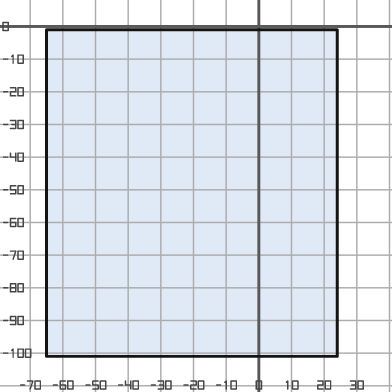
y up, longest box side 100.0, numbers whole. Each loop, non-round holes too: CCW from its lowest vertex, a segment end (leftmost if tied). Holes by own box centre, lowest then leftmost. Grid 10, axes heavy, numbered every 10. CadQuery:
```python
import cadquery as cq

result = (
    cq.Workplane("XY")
    .moveTo(-65.0, -101.0)
    .lineTo(24.0, -101.0)
    .lineTo(24.0, -1.0)
    .lineTo(-65.0, -1.0)
    .close()
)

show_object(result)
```